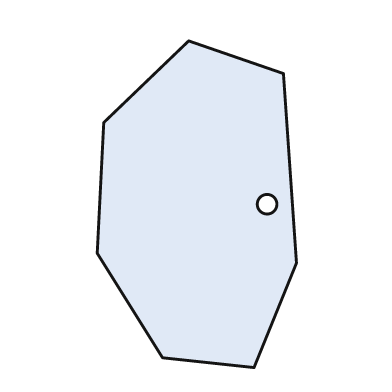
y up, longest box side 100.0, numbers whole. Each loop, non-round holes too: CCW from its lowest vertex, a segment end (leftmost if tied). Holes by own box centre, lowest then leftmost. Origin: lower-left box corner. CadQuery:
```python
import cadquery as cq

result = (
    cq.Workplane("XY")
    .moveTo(48.0, 0.0)
    .lineTo(61.0, 32.0)
    .lineTo(57.0, 90.0)
    .lineTo(28.0, 100.0)
    .lineTo(2.0, 75.0)
    .lineTo(0.0, 35.0)
    .lineTo(20.0, 3.0)
    .close()
    .moveTo(52.0, 50.0)
    .circle(3.0)
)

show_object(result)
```